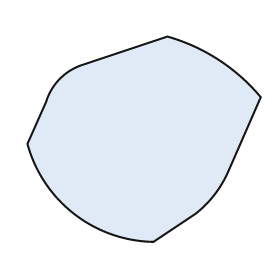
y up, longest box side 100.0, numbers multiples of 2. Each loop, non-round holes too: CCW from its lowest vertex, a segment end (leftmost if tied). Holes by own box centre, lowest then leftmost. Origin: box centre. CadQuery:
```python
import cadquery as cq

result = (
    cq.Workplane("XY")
    .moveTo(4.0, -44.0)
    .lineTo(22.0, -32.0)
    .threePointArc((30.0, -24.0), (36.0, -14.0))
    .lineTo(50.0, 18.0)
    .threePointArc((32.0, 34.0), (10.0, 44.0))
    .lineTo(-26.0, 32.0)
    .threePointArc((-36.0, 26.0), (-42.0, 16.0))
    .lineTo(-50.0, -2.0)
    .threePointArc((-30.0, -32.0), (4.0, -44.0))
    .close()
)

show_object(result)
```